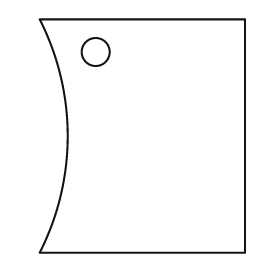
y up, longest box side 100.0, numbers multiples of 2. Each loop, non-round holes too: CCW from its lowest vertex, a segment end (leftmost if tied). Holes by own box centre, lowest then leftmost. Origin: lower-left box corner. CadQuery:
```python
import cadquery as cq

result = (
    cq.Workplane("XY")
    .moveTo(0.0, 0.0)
    .lineTo(88.0, 0.0)
    .lineTo(88.0, 100.0)
    .lineTo(0.0, 100.0)
    .threePointArc((12.0, 50.0), (0.0, 0.0))
    .close()
    .moveTo(24.0, 86.0)
    .circle(6.0)
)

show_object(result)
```